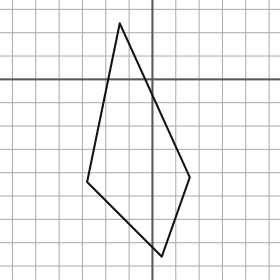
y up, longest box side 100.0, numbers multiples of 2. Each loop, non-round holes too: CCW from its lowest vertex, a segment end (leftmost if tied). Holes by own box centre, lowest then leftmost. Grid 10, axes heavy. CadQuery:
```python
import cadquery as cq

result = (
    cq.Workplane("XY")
    .moveTo(4.0, -76.0)
    .lineTo(16.0, -42.0)
    .lineTo(-14.0, 24.0)
    .lineTo(-28.0, -44.0)
    .close()
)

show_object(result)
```